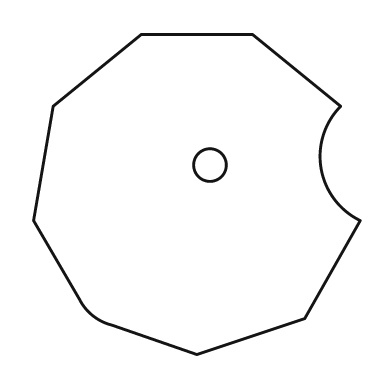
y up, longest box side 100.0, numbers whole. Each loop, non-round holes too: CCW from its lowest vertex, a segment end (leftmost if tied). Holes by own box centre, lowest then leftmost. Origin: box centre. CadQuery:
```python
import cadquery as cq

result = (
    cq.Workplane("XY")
    .moveTo(0.0, -49.0)
    .lineTo(33.0, -38.0)
    .lineTo(50.0, -8.0)
    .threePointArc((38.0, 8.0), (44.0, 27.0))
    .lineTo(17.0, 49.0)
    .lineTo(-17.0, 49.0)
    .lineTo(-44.0, 27.0)
    .lineTo(-50.0, -8.0)
    .lineTo(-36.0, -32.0)
    .threePointArc((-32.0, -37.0), (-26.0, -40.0))
    .close()
    .moveTo(4.0, 9.0)
    .circle(5.0)
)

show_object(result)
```